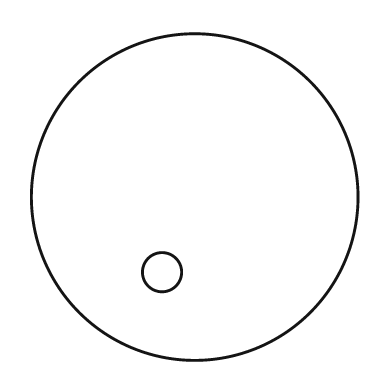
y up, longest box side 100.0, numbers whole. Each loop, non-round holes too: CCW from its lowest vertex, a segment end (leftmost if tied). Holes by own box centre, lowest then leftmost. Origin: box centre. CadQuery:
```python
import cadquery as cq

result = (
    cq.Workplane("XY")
    .moveTo(0.0, 0.0)
    .circle(50.0)
    .moveTo(-10.0, -23.0)
    .circle(6.0)
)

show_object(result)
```